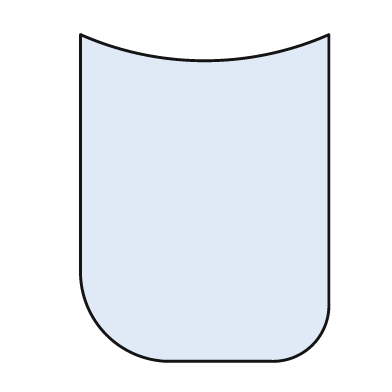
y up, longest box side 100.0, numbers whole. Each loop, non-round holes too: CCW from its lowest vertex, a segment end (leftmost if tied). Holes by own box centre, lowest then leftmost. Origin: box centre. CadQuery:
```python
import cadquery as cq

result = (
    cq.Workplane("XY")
    .moveTo(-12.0, -50.0)
    .lineTo(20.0, -50.0)
    .threePointArc((33.0, -45.0), (38.0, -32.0))
    .lineTo(38.0, 50.0)
    .threePointArc((0.0, 42.0), (-38.0, 50.0))
    .lineTo(-38.0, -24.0)
    .threePointArc((-30.0, -42.0), (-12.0, -50.0))
    .close()
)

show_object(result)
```